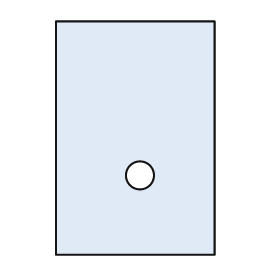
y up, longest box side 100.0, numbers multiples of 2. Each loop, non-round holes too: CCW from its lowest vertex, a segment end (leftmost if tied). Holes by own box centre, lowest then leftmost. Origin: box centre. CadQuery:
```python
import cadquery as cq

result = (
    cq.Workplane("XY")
    .moveTo(-34.0, -50.0)
    .lineTo(34.0, -50.0)
    .lineTo(34.0, 50.0)
    .lineTo(-34.0, 50.0)
    .close()
    .moveTo(2.0, -16.0)
    .circle(6.0)
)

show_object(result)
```